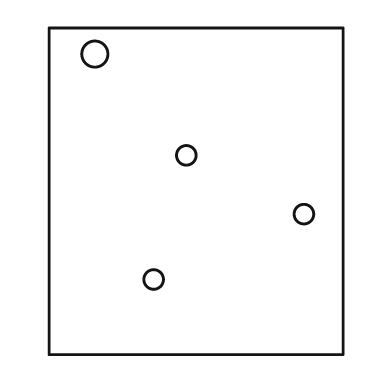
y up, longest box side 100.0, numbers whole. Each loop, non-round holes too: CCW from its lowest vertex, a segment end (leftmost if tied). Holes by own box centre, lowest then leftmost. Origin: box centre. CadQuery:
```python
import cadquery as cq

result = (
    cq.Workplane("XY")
    .moveTo(-45.0, -50.0)
    .lineTo(45.0, -50.0)
    .lineTo(45.0, 50.0)
    .lineTo(-45.0, 50.0)
    .close()
    .moveTo(-13.0, -27.0)
    .circle(3.0)
    .moveTo(33.0, -7.0)
    .circle(3.0)
    .moveTo(-3.0, 11.0)
    .circle(3.0)
    .moveTo(-31.0, 42.0)
    .circle(4.0)
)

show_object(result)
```